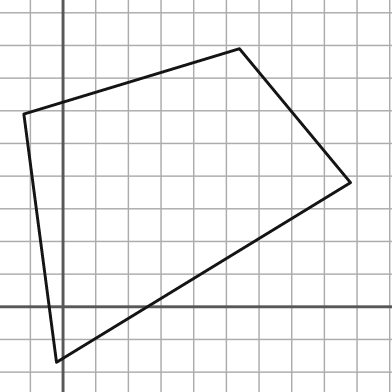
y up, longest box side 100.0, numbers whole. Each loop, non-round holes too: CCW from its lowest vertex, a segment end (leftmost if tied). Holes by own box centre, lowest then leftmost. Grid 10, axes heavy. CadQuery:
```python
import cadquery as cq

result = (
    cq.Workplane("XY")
    .moveTo(-2.0, -17.0)
    .lineTo(88.0, 38.0)
    .lineTo(54.0, 79.0)
    .lineTo(-12.0, 59.0)
    .close()
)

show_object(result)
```